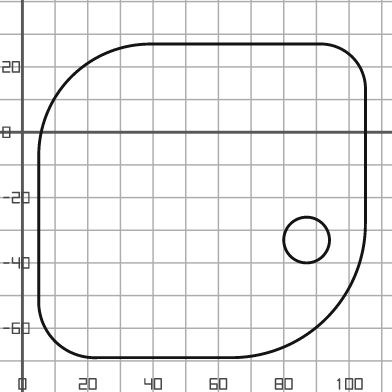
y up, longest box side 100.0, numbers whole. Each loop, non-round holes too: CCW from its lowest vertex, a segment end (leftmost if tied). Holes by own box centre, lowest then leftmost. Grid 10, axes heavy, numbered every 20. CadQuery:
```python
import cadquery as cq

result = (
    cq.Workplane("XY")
    .moveTo(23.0, -69.0)
    .lineTo(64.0, -69.0)
    .threePointArc((93.0, -57.0), (105.0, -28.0))
    .lineTo(105.0, 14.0)
    .threePointArc((101.0, 23.0), (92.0, 27.0))
    .lineTo(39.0, 27.0)
    .threePointArc((15.0, 17.0), (5.0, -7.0))
    .lineTo(5.0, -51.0)
    .threePointArc((10.0, -64.0), (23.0, -69.0))
    .close()
    .moveTo(87.0, -33.0)
    .circle(7.0)
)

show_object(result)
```